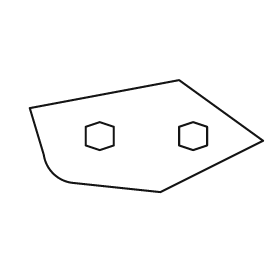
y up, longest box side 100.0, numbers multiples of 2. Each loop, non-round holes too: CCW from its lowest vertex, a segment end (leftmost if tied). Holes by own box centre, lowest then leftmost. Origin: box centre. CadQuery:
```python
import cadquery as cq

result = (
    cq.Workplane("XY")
    .moveTo(6.0, -24.0)
    .lineTo(50.0, -2.0)
    .lineTo(14.0, 24.0)
    .lineTo(-50.0, 12.0)
    .lineTo(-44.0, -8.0)
    .threePointArc((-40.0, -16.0), (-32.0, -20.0))
    .close()
    .moveTo(-20.0, -6.0)
    .lineTo(-14.0, -4.0)
    .lineTo(-14.0, 4.0)
    .lineTo(-20.0, 6.0)
    .lineTo(-26.0, 4.0)
    .lineTo(-26.0, -4.0)
    .close()
    .moveTo(20.0, -6.0)
    .lineTo(26.0, -4.0)
    .lineTo(26.0, 4.0)
    .lineTo(20.0, 6.0)
    .lineTo(14.0, 4.0)
    .lineTo(14.0, -4.0)
    .close()
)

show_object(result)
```